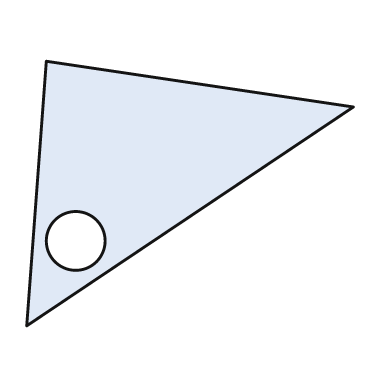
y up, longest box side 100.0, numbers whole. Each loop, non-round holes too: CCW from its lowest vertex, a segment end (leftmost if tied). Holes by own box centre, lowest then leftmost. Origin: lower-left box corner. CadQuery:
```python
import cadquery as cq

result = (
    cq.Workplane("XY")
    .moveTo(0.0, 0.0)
    .lineTo(100.0, 67.0)
    .lineTo(6.0, 81.0)
    .close()
    .moveTo(15.0, 26.0)
    .circle(9.0)
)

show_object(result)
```